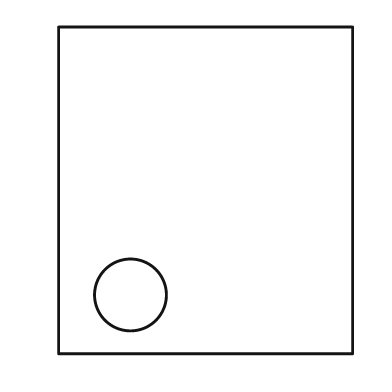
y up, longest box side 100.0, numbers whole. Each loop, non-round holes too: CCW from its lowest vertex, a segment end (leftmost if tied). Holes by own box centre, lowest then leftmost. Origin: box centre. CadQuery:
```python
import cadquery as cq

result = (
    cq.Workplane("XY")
    .moveTo(-45.0, -50.0)
    .lineTo(45.0, -50.0)
    .lineTo(45.0, 50.0)
    .lineTo(-45.0, 50.0)
    .close()
    .moveTo(-23.0, -32.0)
    .circle(11.0)
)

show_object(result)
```